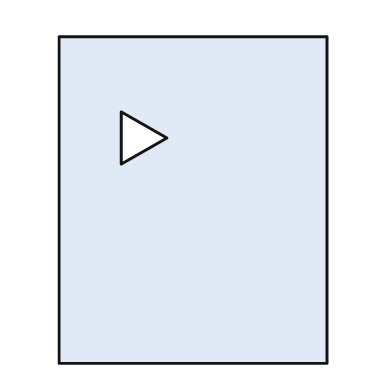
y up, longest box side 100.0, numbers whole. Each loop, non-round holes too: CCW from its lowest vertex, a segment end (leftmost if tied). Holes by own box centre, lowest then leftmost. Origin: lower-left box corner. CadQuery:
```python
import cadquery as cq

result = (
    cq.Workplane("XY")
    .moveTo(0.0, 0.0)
    .lineTo(82.0, 0.0)
    .lineTo(82.0, 100.0)
    .lineTo(0.0, 100.0)
    .close()
    .moveTo(19.0, 61.0)
    .lineTo(33.0, 69.0)
    .lineTo(19.0, 77.0)
    .close()
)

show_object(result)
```